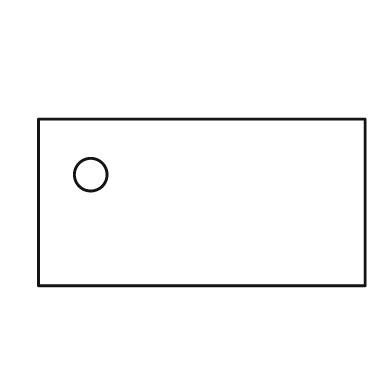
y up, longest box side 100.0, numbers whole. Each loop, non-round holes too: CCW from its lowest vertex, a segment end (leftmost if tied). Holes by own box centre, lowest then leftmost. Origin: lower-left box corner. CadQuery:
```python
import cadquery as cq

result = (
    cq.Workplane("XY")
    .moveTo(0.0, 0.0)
    .lineTo(100.0, 0.0)
    .lineTo(100.0, 51.0)
    .lineTo(0.0, 51.0)
    .close()
    .moveTo(16.0, 34.0)
    .circle(5.0)
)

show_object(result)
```